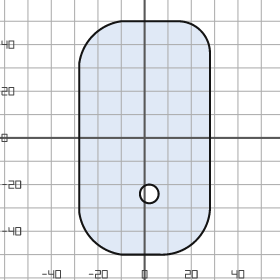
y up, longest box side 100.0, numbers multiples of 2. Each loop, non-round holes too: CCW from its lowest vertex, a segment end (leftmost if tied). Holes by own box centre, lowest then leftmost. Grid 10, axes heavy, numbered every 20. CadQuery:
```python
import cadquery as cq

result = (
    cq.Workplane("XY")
    .moveTo(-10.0, -50.0)
    .lineTo(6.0, -50.0)
    .threePointArc((22.0, -44.0), (28.0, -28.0))
    .lineTo(28.0, 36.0)
    .threePointArc((24.0, 46.0), (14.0, 50.0))
    .lineTo(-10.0, 50.0)
    .threePointArc((-22.0, 44.0), (-28.0, 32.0))
    .lineTo(-28.0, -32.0)
    .threePointArc((-22.0, -44.0), (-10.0, -50.0))
    .close()
    .moveTo(2.0, -24.0)
    .circle(4.0)
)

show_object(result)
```